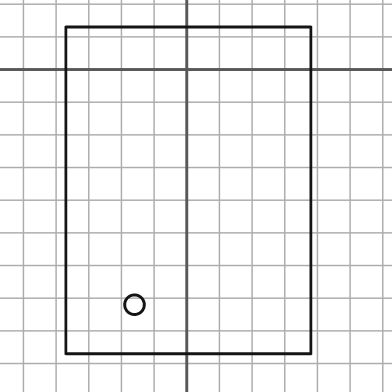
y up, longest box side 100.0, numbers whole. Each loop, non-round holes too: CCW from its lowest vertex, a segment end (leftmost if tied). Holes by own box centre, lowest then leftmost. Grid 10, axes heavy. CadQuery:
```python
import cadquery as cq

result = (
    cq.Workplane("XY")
    .moveTo(-37.0, -87.0)
    .lineTo(38.0, -87.0)
    .lineTo(38.0, 13.0)
    .lineTo(-37.0, 13.0)
    .close()
    .moveTo(-16.0, -72.0)
    .circle(3.0)
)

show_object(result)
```